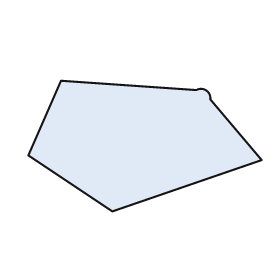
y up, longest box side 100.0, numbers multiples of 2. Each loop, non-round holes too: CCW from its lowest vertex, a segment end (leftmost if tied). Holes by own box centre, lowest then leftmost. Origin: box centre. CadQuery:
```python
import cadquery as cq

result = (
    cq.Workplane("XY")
    .moveTo(-14.0, -28.0)
    .lineTo(50.0, -6.0)
    .lineTo(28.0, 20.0)
    .threePointArc((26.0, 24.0), (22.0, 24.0))
    .lineTo(-36.0, 28.0)
    .lineTo(-50.0, -4.0)
    .close()
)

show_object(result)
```